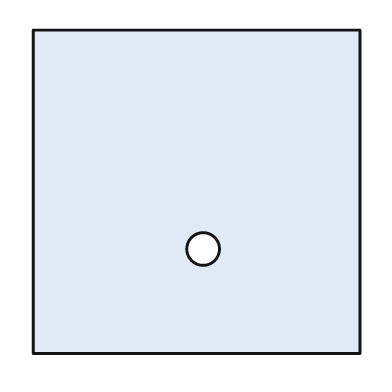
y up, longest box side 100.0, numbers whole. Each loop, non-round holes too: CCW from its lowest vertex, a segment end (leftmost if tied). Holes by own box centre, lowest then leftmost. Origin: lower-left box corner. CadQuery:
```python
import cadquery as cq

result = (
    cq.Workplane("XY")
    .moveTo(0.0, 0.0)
    .lineTo(100.0, 0.0)
    .lineTo(100.0, 99.0)
    .lineTo(0.0, 99.0)
    .close()
    .moveTo(52.0, 32.0)
    .circle(5.0)
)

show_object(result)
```